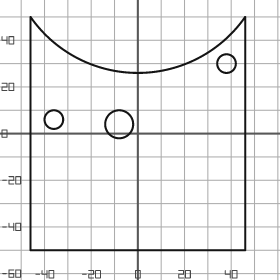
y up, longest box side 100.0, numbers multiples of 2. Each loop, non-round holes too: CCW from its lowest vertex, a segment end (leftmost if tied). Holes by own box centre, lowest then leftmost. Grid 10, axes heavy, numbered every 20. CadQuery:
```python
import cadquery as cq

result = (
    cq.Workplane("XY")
    .moveTo(-46.0, -50.0)
    .lineTo(46.0, -50.0)
    .lineTo(46.0, 50.0)
    .threePointArc((0.0, 26.0), (-46.0, 50.0))
    .close()
    .moveTo(-8.0, 4.0)
    .circle(6.0)
    .moveTo(-36.0, 6.0)
    .circle(4.0)
    .moveTo(38.0, 30.0)
    .circle(4.0)
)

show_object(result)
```